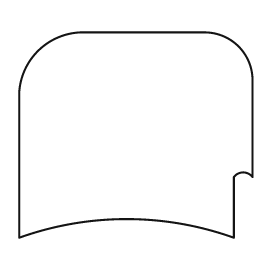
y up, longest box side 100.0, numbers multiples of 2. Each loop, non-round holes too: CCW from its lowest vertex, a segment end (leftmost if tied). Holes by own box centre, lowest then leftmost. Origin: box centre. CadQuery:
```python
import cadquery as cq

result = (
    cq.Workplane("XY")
    .moveTo(-50.0, -44.0)
    .threePointArc((-4.0, -36.0), (42.0, -44.0))
    .lineTo(42.0, -18.0)
    .threePointArc((46.0, -16.0), (50.0, -18.0))
    .lineTo(50.0, 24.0)
    .threePointArc((44.0, 38.0), (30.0, 44.0))
    .lineTo(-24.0, 44.0)
    .threePointArc((-42.0, 36.0), (-50.0, 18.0))
    .close()
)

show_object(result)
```